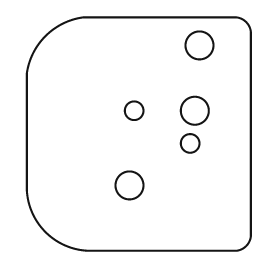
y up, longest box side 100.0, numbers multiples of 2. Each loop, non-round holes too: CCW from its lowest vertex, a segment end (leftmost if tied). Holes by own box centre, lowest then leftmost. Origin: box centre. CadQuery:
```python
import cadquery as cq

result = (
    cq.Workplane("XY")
    .moveTo(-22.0, -50.0)
    .lineTo(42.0, -50.0)
    .threePointArc((46.0, -48.0), (48.0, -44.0))
    .lineTo(48.0, 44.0)
    .threePointArc((46.0, 48.0), (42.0, 50.0))
    .lineTo(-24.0, 50.0)
    .threePointArc((-40.0, 42.0), (-48.0, 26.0))
    .lineTo(-48.0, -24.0)
    .threePointArc((-40.0, -42.0), (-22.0, -50.0))
    .close()
    .moveTo(-4.0, -22.0)
    .circle(6.0)
    .moveTo(22.0, -4.0)
    .circle(4.0)
    .moveTo(-2.0, 10.0)
    .circle(4.0)
    .moveTo(24.0, 10.0)
    .circle(6.0)
    .moveTo(26.0, 38.0)
    .circle(6.0)
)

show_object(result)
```